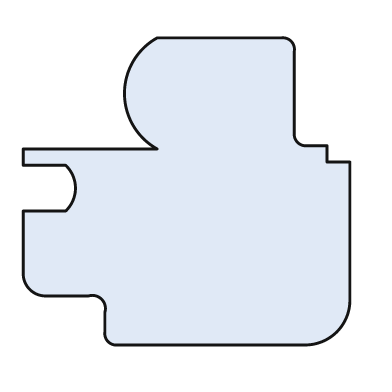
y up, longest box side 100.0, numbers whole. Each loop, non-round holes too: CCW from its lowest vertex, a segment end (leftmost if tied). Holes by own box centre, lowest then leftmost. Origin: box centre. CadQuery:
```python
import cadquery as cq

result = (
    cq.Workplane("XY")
    .moveTo(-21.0, -47.0)
    .lineTo(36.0, -47.0)
    .threePointArc((46.0, -43.0), (50.0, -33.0))
    .lineTo(50.0, 9.0)
    .lineTo(43.0, 9.0)
    .lineTo(43.0, 14.0)
    .lineTo(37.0, 14.0)
    .threePointArc((34.0, 15.0), (33.0, 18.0))
    .lineTo(33.0, 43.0)
    .threePointArc((32.0, 46.0), (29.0, 47.0))
    .lineTo(-9.0, 47.0)
    .threePointArc((-19.0, 30.0), (-9.0, 13.0))
    .lineTo(-50.0, 13.0)
    .lineTo(-50.0, 8.0)
    .lineTo(-37.0, 8.0)
    .threePointArc((-34.0, 1.0), (-37.0, -6.0))
    .lineTo(-50.0, -6.0)
    .lineTo(-50.0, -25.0)
    .threePointArc((-48.0, -30.0), (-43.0, -32.0))
    .lineTo(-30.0, -32.0)
    .threePointArc((-26.0, -33.0), (-25.0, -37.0))
    .lineTo(-25.0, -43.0)
    .threePointArc((-24.0, -46.0), (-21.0, -47.0))
    .close()
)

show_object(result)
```